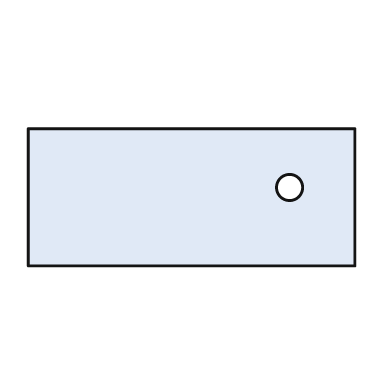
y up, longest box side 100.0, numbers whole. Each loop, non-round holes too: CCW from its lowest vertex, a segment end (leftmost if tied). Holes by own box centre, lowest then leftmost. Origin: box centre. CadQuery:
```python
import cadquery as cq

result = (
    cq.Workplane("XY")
    .moveTo(-50.0, -21.0)
    .lineTo(50.0, -21.0)
    .lineTo(50.0, 21.0)
    .lineTo(-50.0, 21.0)
    .close()
    .moveTo(30.0, 3.0)
    .circle(4.0)
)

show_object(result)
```